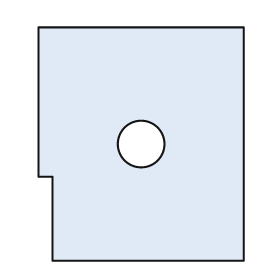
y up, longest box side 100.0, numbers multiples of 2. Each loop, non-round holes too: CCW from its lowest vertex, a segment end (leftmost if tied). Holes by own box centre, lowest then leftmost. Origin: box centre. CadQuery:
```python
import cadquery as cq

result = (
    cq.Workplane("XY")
    .moveTo(-38.0, -50.0)
    .lineTo(44.0, -50.0)
    .lineTo(44.0, 50.0)
    .lineTo(-44.0, 50.0)
    .lineTo(-44.0, -14.0)
    .lineTo(-38.0, -14.0)
    .close()
    .moveTo(0.0, 0.0)
    .circle(10.0)
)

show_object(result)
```